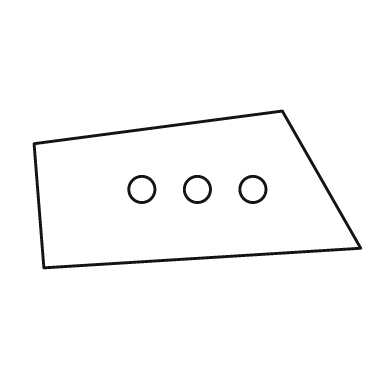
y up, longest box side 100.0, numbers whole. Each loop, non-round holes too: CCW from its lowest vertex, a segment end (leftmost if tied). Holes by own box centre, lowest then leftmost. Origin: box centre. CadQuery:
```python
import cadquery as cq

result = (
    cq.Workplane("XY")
    .moveTo(-47.0, -24.0)
    .lineTo(50.0, -18.0)
    .lineTo(26.0, 24.0)
    .lineTo(-50.0, 14.0)
    .close()
    .moveTo(-17.0, 0.0)
    .circle(4.0)
    .moveTo(0.0, 0.0)
    .circle(4.0)
    .moveTo(17.0, 0.0)
    .circle(4.0)
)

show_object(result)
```